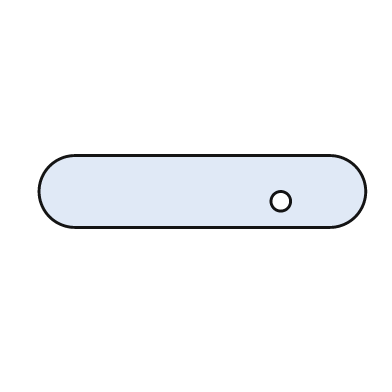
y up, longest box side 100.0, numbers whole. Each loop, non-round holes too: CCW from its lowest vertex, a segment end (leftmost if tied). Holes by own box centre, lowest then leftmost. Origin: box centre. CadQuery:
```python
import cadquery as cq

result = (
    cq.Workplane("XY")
    .moveTo(-39.0, -11.0)
    .lineTo(39.0, -11.0)
    .threePointArc((50.0, 0.0), (39.0, 11.0))
    .lineTo(-39.0, 11.0)
    .threePointArc((-50.0, 0.0), (-39.0, -11.0))
    .close()
    .moveTo(24.0, -3.0)
    .circle(3.0)
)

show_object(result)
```